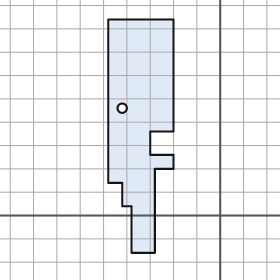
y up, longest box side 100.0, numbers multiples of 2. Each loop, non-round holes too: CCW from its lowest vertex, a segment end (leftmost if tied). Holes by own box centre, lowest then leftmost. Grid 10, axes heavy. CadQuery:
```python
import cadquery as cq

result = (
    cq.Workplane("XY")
    .moveTo(-38.0, -16.0)
    .lineTo(-28.0, -16.0)
    .lineTo(-28.0, 20.0)
    .lineTo(-20.0, 20.0)
    .lineTo(-20.0, 26.0)
    .lineTo(-30.0, 26.0)
    .lineTo(-30.0, 36.0)
    .lineTo(-20.0, 36.0)
    .lineTo(-20.0, 84.0)
    .lineTo(-48.0, 84.0)
    .lineTo(-48.0, 14.0)
    .lineTo(-42.0, 14.0)
    .lineTo(-42.0, 4.0)
    .lineTo(-38.0, 4.0)
    .close()
    .moveTo(-42.0, 46.0)
    .circle(2.0)
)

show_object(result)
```